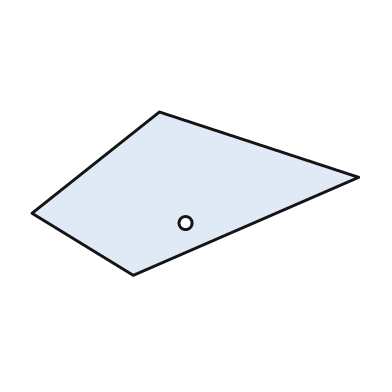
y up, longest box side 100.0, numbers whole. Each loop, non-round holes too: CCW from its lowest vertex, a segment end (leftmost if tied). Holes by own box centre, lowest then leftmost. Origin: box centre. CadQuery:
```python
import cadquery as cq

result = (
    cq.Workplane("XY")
    .moveTo(-19.0, -25.0)
    .lineTo(50.0, 5.0)
    .lineTo(-11.0, 25.0)
    .lineTo(-50.0, -6.0)
    .close()
    .moveTo(-3.0, -9.0)
    .circle(2.0)
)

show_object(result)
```